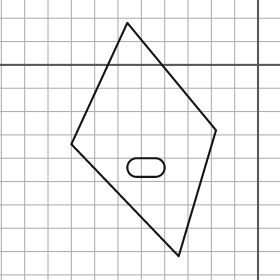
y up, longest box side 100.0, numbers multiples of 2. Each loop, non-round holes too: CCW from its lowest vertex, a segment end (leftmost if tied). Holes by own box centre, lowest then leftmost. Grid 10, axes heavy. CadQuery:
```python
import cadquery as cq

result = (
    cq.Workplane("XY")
    .moveTo(-34.0, -82.0)
    .lineTo(-18.0, -28.0)
    .lineTo(-56.0, 18.0)
    .lineTo(-80.0, -34.0)
    .close()
    .moveTo(-52.0, -48.0)
    .lineTo(-44.0, -48.0)
    .threePointArc((-40.0, -44.0), (-44.0, -40.0))
    .lineTo(-52.0, -40.0)
    .threePointArc((-56.0, -44.0), (-52.0, -48.0))
    .close()
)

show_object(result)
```